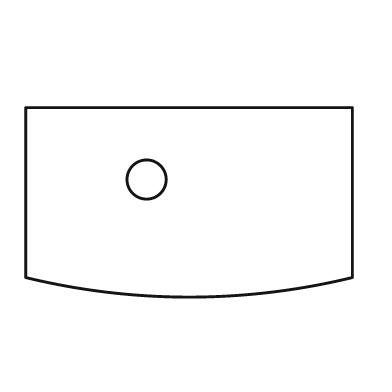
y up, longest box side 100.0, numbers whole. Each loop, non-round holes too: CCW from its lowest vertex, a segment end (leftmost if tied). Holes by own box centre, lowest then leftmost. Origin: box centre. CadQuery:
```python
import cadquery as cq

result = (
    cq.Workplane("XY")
    .moveTo(-50.0, -23.0)
    .threePointArc((0.0, -29.0), (50.0, -23.0))
    .lineTo(50.0, 29.0)
    .lineTo(-50.0, 29.0)
    .close()
    .moveTo(-13.0, 7.0)
    .circle(6.0)
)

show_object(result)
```